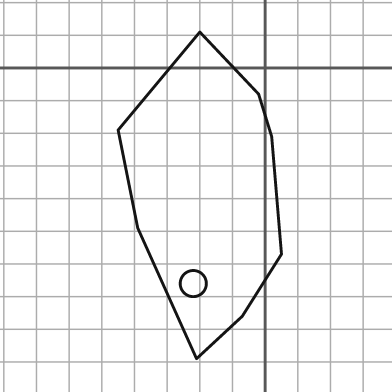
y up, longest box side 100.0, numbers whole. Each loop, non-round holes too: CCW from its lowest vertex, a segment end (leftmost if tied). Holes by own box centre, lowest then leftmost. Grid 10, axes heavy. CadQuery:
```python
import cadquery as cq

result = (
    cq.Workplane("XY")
    .moveTo(-21.0, -89.0)
    .lineTo(-7.0, -76.0)
    .lineTo(5.0, -57.0)
    .lineTo(2.0, -21.0)
    .lineTo(-2.0, -8.0)
    .lineTo(-20.0, 11.0)
    .lineTo(-45.0, -19.0)
    .lineTo(-39.0, -49.0)
    .close()
    .moveTo(-22.0, -66.0)
    .circle(4.0)
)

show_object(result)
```